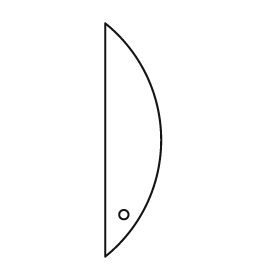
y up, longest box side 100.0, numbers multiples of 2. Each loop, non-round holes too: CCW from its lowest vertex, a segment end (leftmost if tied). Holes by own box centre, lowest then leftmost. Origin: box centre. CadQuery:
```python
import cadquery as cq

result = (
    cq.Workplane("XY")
    .moveTo(-12.0, -50.0)
    .threePointArc((12.0, 0.0), (-12.0, 50.0))
    .close()
    .moveTo(-4.0, -32.0)
    .circle(2.0)
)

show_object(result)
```